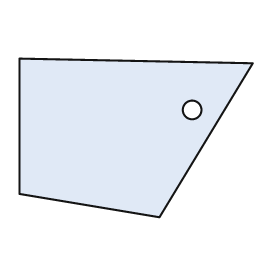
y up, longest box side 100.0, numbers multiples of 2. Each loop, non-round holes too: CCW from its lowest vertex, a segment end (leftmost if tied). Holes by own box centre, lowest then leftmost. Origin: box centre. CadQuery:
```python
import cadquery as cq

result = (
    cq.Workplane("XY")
    .moveTo(10.0, -34.0)
    .lineTo(50.0, 32.0)
    .lineTo(-50.0, 34.0)
    .lineTo(-50.0, -24.0)
    .close()
    .moveTo(24.0, 12.0)
    .circle(4.0)
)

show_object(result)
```